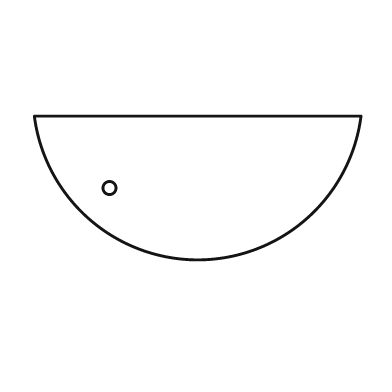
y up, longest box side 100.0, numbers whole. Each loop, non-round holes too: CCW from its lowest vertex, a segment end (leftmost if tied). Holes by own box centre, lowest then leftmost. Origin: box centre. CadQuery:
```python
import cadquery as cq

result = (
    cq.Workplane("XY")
    .moveTo(-50.0, 22.0)
    .threePointArc((0.0, -22.0), (50.0, 22.0))
    .close()
    .moveTo(-27.0, 0.0)
    .circle(2.0)
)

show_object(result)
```